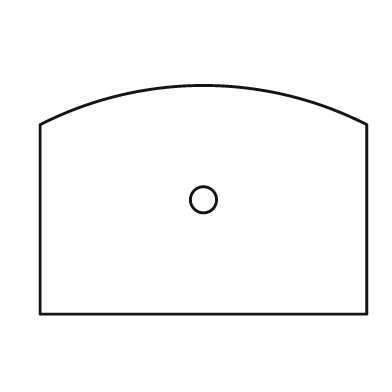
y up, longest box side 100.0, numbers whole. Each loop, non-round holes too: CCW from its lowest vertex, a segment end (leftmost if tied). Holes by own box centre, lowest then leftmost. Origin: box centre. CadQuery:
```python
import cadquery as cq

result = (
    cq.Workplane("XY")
    .moveTo(-50.0, -35.0)
    .lineTo(50.0, -35.0)
    .lineTo(50.0, 23.0)
    .threePointArc((0.0, 35.0), (-50.0, 23.0))
    .close()
    .moveTo(0.0, 0.0)
    .circle(4.0)
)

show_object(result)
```